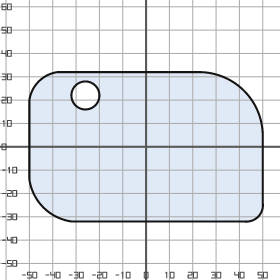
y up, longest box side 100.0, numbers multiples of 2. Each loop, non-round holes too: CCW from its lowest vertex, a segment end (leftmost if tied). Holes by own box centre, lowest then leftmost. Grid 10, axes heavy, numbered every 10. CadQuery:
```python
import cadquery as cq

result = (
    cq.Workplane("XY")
    .moveTo(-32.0, -32.0)
    .lineTo(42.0, -32.0)
    .threePointArc((48.0, -30.0), (50.0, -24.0))
    .lineTo(50.0, 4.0)
    .threePointArc((42.0, 24.0), (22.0, 32.0))
    .lineTo(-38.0, 32.0)
    .threePointArc((-46.0, 28.0), (-50.0, 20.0))
    .lineTo(-50.0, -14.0)
    .threePointArc((-44.0, -26.0), (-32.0, -32.0))
    .close()
    .moveTo(-26.0, 22.0)
    .circle(6.0)
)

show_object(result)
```